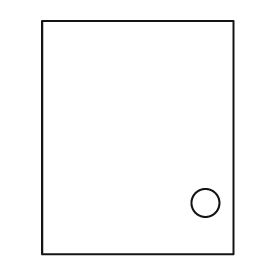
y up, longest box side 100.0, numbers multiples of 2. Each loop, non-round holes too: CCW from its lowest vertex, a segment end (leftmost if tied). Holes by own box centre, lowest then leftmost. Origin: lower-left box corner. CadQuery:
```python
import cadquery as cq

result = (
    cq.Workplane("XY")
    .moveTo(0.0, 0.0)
    .lineTo(82.0, 0.0)
    .lineTo(82.0, 100.0)
    .lineTo(0.0, 100.0)
    .close()
    .moveTo(70.0, 22.0)
    .circle(6.0)
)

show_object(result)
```